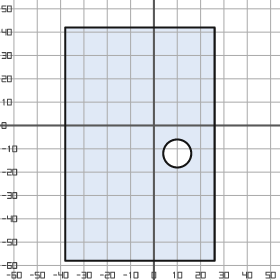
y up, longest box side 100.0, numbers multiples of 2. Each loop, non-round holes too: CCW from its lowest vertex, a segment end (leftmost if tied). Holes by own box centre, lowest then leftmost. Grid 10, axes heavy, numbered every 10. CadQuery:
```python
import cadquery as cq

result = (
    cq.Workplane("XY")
    .moveTo(-38.0, -58.0)
    .lineTo(26.0, -58.0)
    .lineTo(26.0, 42.0)
    .lineTo(-38.0, 42.0)
    .close()
    .moveTo(10.0, -12.0)
    .circle(6.0)
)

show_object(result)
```